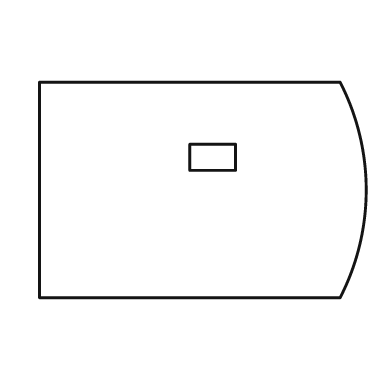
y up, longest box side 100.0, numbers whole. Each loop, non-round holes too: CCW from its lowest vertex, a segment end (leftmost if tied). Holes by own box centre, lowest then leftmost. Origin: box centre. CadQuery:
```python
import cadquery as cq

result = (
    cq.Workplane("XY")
    .moveTo(-50.0, -33.0)
    .lineTo(42.0, -33.0)
    .threePointArc((50.0, 0.0), (42.0, 33.0))
    .lineTo(-50.0, 33.0)
    .close()
    .moveTo(-4.0, 6.0)
    .lineTo(10.0, 6.0)
    .lineTo(10.0, 14.0)
    .lineTo(-4.0, 14.0)
    .close()
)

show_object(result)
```